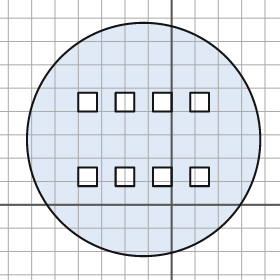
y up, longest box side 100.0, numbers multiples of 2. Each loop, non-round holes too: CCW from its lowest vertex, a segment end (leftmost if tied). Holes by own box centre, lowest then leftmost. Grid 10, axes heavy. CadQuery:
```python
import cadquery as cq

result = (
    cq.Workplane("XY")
    .moveTo(-12.0, 28.0)
    .circle(50.0)
    .moveTo(-40.0, 8.0)
    .lineTo(-32.0, 8.0)
    .lineTo(-32.0, 16.0)
    .lineTo(-40.0, 16.0)
    .close()
    .moveTo(-24.0, 8.0)
    .lineTo(-16.0, 8.0)
    .lineTo(-16.0, 16.0)
    .lineTo(-24.0, 16.0)
    .close()
    .moveTo(-8.0, 8.0)
    .lineTo(0.0, 8.0)
    .lineTo(0.0, 16.0)
    .lineTo(-8.0, 16.0)
    .close()
    .moveTo(8.0, 8.0)
    .lineTo(16.0, 8.0)
    .lineTo(16.0, 16.0)
    .lineTo(8.0, 16.0)
    .close()
    .moveTo(-40.0, 40.0)
    .lineTo(-32.0, 40.0)
    .lineTo(-32.0, 48.0)
    .lineTo(-40.0, 48.0)
    .close()
    .moveTo(-24.0, 40.0)
    .lineTo(-16.0, 40.0)
    .lineTo(-16.0, 48.0)
    .lineTo(-24.0, 48.0)
    .close()
    .moveTo(-8.0, 40.0)
    .lineTo(0.0, 40.0)
    .lineTo(0.0, 48.0)
    .lineTo(-8.0, 48.0)
    .close()
    .moveTo(8.0, 40.0)
    .lineTo(16.0, 40.0)
    .lineTo(16.0, 48.0)
    .lineTo(8.0, 48.0)
    .close()
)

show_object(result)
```